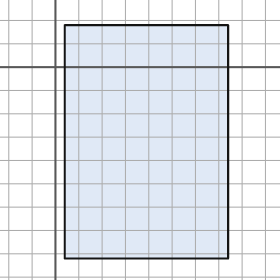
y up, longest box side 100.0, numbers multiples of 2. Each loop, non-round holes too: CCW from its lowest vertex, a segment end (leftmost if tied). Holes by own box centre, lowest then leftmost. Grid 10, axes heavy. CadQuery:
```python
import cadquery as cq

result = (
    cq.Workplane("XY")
    .moveTo(4.0, -82.0)
    .lineTo(74.0, -82.0)
    .lineTo(74.0, 18.0)
    .lineTo(4.0, 18.0)
    .close()
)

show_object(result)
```